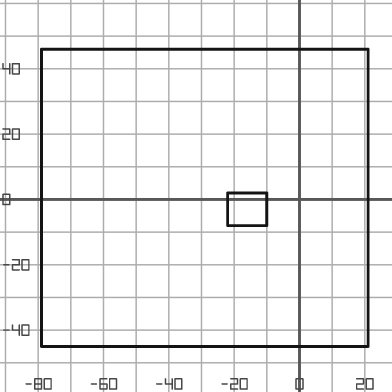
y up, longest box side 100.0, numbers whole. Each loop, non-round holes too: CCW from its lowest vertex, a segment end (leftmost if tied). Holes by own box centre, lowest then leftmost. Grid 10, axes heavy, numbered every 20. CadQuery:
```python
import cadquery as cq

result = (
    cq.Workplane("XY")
    .moveTo(-79.0, -45.0)
    .lineTo(21.0, -45.0)
    .lineTo(21.0, 46.0)
    .lineTo(-79.0, 46.0)
    .close()
    .moveTo(-22.0, -8.0)
    .lineTo(-10.0, -8.0)
    .lineTo(-10.0, 2.0)
    .lineTo(-22.0, 2.0)
    .close()
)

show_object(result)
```